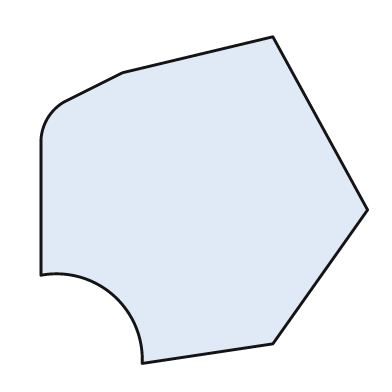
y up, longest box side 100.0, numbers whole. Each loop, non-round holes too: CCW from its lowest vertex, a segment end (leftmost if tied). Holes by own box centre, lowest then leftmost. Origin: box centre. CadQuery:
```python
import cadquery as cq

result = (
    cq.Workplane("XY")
    .moveTo(-19.0, -50.0)
    .lineTo(21.0, -44.0)
    .lineTo(50.0, -3.0)
    .lineTo(21.0, 50.0)
    .lineTo(-25.0, 39.0)
    .lineTo(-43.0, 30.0)
    .threePointArc((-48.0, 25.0), (-50.0, 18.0))
    .lineTo(-50.0, -23.0)
    .threePointArc((-28.0, -29.0), (-19.0, -50.0))
    .close()
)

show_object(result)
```